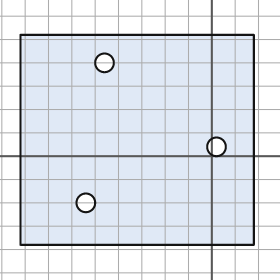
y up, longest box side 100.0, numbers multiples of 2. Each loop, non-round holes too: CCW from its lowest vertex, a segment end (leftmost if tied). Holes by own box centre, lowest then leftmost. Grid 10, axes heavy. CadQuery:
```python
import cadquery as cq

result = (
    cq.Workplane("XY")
    .moveTo(-82.0, -38.0)
    .lineTo(18.0, -38.0)
    .lineTo(18.0, 52.0)
    .lineTo(-82.0, 52.0)
    .close()
    .moveTo(-54.0, -20.0)
    .circle(4.0)
    .moveTo(2.0, 4.0)
    .circle(4.0)
    .moveTo(-46.0, 40.0)
    .circle(4.0)
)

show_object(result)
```